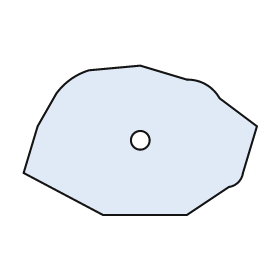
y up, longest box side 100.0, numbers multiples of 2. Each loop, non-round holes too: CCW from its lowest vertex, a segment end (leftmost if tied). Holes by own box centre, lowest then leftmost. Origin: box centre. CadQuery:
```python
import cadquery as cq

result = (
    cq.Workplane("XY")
    .moveTo(-16.0, -32.0)
    .lineTo(20.0, -32.0)
    .lineTo(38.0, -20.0)
    .threePointArc((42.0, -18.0), (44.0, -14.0))
    .lineTo(50.0, 6.0)
    .lineTo(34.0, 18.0)
    .threePointArc((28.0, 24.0), (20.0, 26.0))
    .lineTo(0.0, 32.0)
    .lineTo(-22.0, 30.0)
    .threePointArc((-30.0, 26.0), (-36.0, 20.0))
    .lineTo(-44.0, 6.0)
    .lineTo(-50.0, -14.0)
    .close()
    .moveTo(0.0, 0.0)
    .circle(4.0)
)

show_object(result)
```